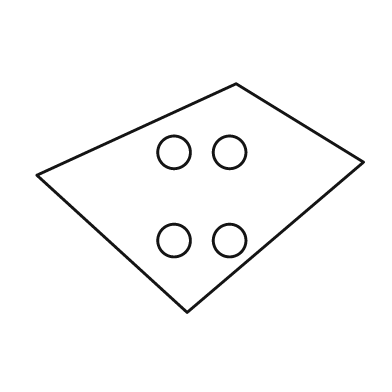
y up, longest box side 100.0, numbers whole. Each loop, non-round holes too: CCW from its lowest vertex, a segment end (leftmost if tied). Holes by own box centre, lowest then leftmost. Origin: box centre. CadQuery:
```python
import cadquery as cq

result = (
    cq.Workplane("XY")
    .moveTo(-4.0, -35.0)
    .lineTo(50.0, 11.0)
    .lineTo(11.0, 35.0)
    .lineTo(-50.0, 7.0)
    .close()
    .moveTo(-8.0, -13.0)
    .circle(5.0)
    .moveTo(9.0, -13.0)
    .circle(5.0)
    .moveTo(-8.0, 14.0)
    .circle(5.0)
    .moveTo(9.0, 14.0)
    .circle(5.0)
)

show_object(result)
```